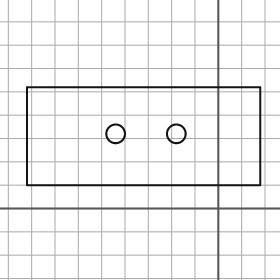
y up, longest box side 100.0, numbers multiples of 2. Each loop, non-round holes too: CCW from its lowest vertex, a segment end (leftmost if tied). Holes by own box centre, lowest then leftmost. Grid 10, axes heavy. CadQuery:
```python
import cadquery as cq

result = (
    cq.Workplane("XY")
    .moveTo(-82.0, 10.0)
    .lineTo(18.0, 10.0)
    .lineTo(18.0, 52.0)
    .lineTo(-82.0, 52.0)
    .close()
    .moveTo(-44.0, 32.0)
    .circle(4.0)
    .moveTo(-18.0, 32.0)
    .circle(4.0)
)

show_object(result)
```